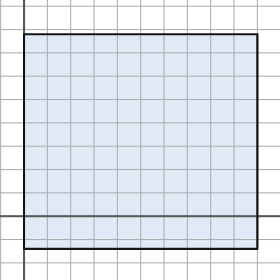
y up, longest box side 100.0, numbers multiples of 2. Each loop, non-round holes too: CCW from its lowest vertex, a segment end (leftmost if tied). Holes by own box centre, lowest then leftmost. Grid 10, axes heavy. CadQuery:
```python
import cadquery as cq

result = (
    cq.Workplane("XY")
    .moveTo(0.0, -14.0)
    .lineTo(100.0, -14.0)
    .lineTo(100.0, 78.0)
    .lineTo(0.0, 78.0)
    .close()
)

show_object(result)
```